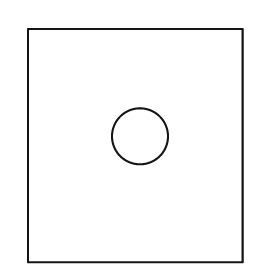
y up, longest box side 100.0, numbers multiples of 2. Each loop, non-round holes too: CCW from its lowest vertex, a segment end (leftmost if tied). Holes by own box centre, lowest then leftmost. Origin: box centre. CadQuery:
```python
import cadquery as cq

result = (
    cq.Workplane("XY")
    .moveTo(-46.0, -50.0)
    .lineTo(46.0, -50.0)
    .lineTo(46.0, 50.0)
    .lineTo(-46.0, 50.0)
    .close()
    .moveTo(2.0, 4.0)
    .circle(12.0)
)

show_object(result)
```